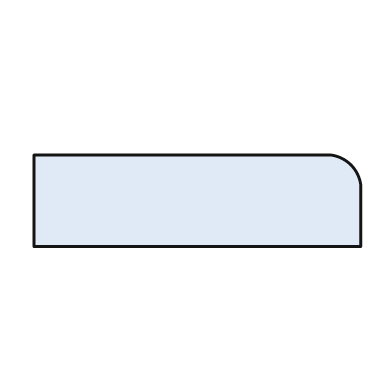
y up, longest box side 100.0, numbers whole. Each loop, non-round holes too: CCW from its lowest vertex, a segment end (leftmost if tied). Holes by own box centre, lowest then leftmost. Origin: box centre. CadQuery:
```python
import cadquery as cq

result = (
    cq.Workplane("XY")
    .moveTo(-50.0, -14.0)
    .lineTo(50.0, -14.0)
    .lineTo(50.0, 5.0)
    .threePointArc((47.0, 11.0), (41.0, 14.0))
    .lineTo(-50.0, 14.0)
    .close()
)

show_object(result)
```